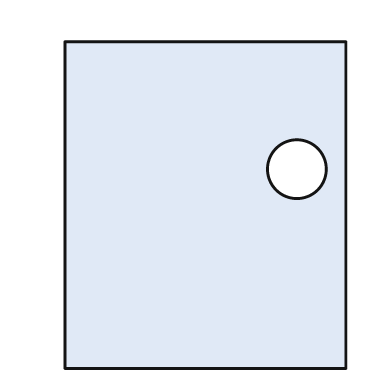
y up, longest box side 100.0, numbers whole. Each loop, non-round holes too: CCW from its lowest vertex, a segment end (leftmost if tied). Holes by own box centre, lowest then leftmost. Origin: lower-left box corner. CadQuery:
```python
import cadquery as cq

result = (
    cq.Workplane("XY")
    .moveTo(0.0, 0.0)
    .lineTo(86.0, 0.0)
    .lineTo(86.0, 100.0)
    .lineTo(0.0, 100.0)
    .close()
    .moveTo(71.0, 61.0)
    .circle(9.0)
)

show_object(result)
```